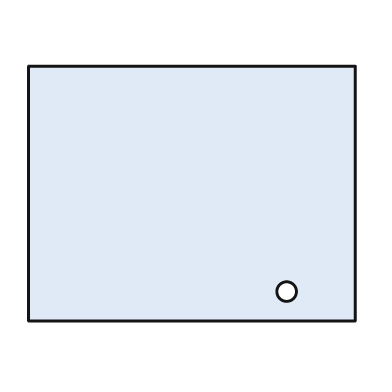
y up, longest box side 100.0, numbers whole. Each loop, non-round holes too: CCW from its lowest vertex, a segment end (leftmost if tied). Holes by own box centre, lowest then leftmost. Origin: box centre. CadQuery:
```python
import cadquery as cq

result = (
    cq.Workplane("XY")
    .moveTo(-50.0, -39.0)
    .lineTo(50.0, -39.0)
    .lineTo(50.0, 39.0)
    .lineTo(-50.0, 39.0)
    .close()
    .moveTo(29.0, -30.0)
    .circle(3.0)
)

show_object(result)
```